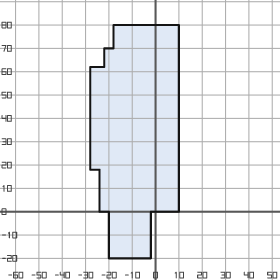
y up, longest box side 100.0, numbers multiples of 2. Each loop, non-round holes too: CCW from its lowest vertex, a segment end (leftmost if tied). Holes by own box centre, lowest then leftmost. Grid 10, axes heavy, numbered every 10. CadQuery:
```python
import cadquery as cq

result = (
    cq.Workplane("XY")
    .moveTo(-20.0, -20.0)
    .lineTo(-2.0, -20.0)
    .lineTo(-2.0, 0.0)
    .lineTo(10.0, 0.0)
    .lineTo(10.0, 80.0)
    .lineTo(-18.0, 80.0)
    .lineTo(-18.0, 70.0)
    .lineTo(-22.0, 70.0)
    .lineTo(-22.0, 62.0)
    .lineTo(-28.0, 62.0)
    .lineTo(-28.0, 18.0)
    .lineTo(-24.0, 18.0)
    .lineTo(-24.0, 0.0)
    .lineTo(-20.0, 0.0)
    .close()
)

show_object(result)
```